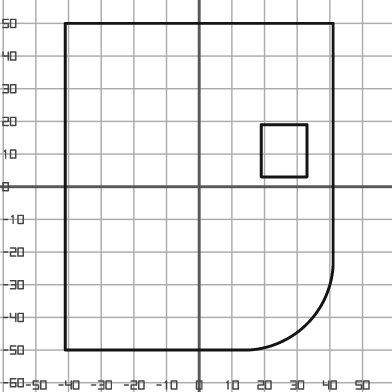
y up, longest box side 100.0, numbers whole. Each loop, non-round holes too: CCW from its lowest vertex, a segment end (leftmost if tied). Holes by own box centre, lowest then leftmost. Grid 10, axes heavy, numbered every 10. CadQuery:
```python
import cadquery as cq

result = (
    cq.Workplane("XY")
    .moveTo(-41.0, -50.0)
    .lineTo(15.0, -50.0)
    .threePointArc((33.0, -42.0), (41.0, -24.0))
    .lineTo(41.0, 50.0)
    .lineTo(-41.0, 50.0)
    .close()
    .moveTo(19.0, 3.0)
    .lineTo(33.0, 3.0)
    .lineTo(33.0, 19.0)
    .lineTo(19.0, 19.0)
    .close()
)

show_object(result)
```